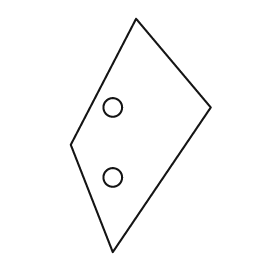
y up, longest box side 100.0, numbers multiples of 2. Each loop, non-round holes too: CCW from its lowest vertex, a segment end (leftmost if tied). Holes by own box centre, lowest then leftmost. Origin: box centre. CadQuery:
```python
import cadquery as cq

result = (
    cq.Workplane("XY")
    .moveTo(-12.0, -50.0)
    .lineTo(30.0, 12.0)
    .lineTo(-2.0, 50.0)
    .lineTo(-30.0, -4.0)
    .close()
    .moveTo(-12.0, -18.0)
    .circle(4.0)
    .moveTo(-12.0, 12.0)
    .circle(4.0)
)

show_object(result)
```